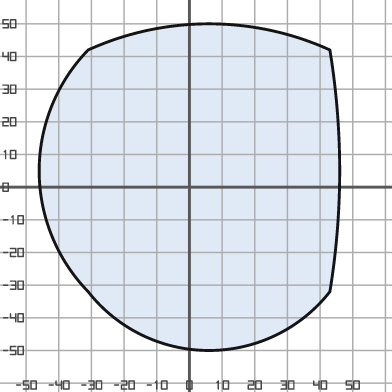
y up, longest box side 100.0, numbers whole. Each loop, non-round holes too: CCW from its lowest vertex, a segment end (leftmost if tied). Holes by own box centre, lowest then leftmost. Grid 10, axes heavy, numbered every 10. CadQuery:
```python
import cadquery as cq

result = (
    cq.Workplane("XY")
    .moveTo(-31.0, -32.0)
    .threePointArc((6.0, -50.0), (43.0, -32.0))
    .threePointArc((46.0, 5.0), (43.0, 42.0))
    .threePointArc((6.0, 50.0), (-31.0, 42.0))
    .threePointArc((-46.0, 5.0), (-31.0, -32.0))
    .close()
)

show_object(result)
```